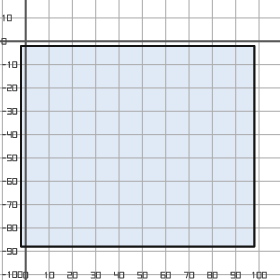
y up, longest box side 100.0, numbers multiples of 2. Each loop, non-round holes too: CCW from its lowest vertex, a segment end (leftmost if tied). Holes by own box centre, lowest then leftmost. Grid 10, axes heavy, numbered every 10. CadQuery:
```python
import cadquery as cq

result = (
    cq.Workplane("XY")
    .moveTo(-2.0, -88.0)
    .lineTo(98.0, -88.0)
    .lineTo(98.0, -2.0)
    .lineTo(-2.0, -2.0)
    .close()
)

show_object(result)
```